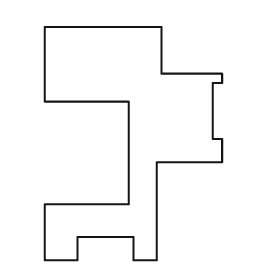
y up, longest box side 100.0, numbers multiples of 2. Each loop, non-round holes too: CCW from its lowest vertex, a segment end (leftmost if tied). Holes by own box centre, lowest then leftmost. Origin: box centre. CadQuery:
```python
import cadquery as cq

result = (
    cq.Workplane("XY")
    .moveTo(-38.0, -50.0)
    .lineTo(-24.0, -50.0)
    .lineTo(-24.0, -40.0)
    .lineTo(0.0, -40.0)
    .lineTo(0.0, -50.0)
    .lineTo(10.0, -50.0)
    .lineTo(10.0, -8.0)
    .lineTo(38.0, -8.0)
    .lineTo(38.0, 2.0)
    .lineTo(34.0, 2.0)
    .lineTo(34.0, 26.0)
    .lineTo(38.0, 26.0)
    .lineTo(38.0, 30.0)
    .lineTo(12.0, 30.0)
    .lineTo(12.0, 50.0)
    .lineTo(-38.0, 50.0)
    .lineTo(-38.0, 18.0)
    .lineTo(-2.0, 18.0)
    .lineTo(-2.0, -26.0)
    .lineTo(-38.0, -26.0)
    .close()
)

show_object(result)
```